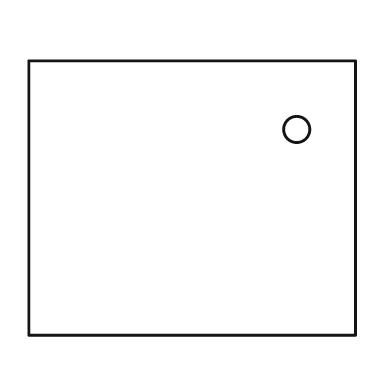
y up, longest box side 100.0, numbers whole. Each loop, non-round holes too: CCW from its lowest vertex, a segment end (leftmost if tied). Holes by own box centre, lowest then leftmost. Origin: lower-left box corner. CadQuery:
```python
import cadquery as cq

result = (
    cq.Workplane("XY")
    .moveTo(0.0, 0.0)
    .lineTo(100.0, 0.0)
    .lineTo(100.0, 84.0)
    .lineTo(0.0, 84.0)
    .close()
    .moveTo(82.0, 63.0)
    .circle(4.0)
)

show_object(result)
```